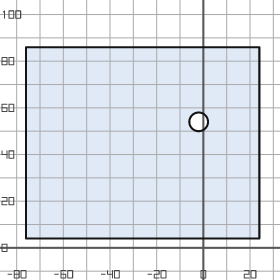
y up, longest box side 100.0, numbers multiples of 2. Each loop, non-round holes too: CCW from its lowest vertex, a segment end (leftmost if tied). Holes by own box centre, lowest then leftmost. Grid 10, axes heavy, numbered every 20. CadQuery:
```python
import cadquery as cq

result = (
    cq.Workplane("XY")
    .moveTo(-76.0, 4.0)
    .lineTo(24.0, 4.0)
    .lineTo(24.0, 86.0)
    .lineTo(-76.0, 86.0)
    .close()
    .moveTo(-2.0, 54.0)
    .circle(4.0)
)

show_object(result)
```